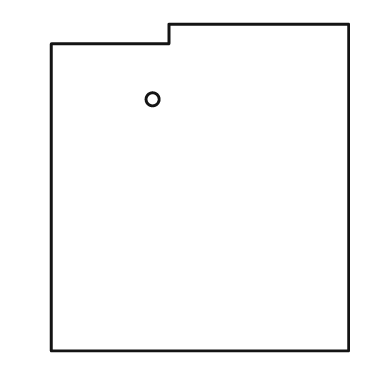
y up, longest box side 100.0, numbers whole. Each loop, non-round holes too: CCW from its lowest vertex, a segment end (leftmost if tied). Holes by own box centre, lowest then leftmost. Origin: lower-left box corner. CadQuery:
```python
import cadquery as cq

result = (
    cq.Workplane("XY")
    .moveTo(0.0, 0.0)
    .lineTo(91.0, 0.0)
    .lineTo(91.0, 100.0)
    .lineTo(36.0, 100.0)
    .lineTo(36.0, 94.0)
    .lineTo(0.0, 94.0)
    .close()
    .moveTo(31.0, 77.0)
    .circle(2.0)
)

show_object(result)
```